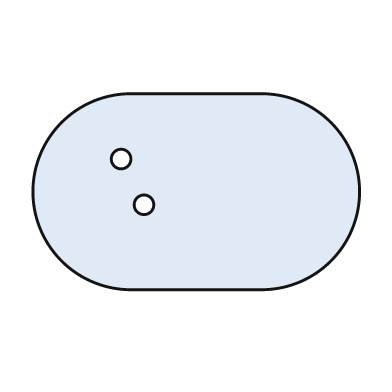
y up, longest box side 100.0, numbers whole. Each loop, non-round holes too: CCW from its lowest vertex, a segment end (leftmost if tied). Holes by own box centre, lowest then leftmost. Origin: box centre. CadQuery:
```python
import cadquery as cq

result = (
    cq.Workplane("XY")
    .moveTo(-20.0, -30.0)
    .lineTo(20.0, -30.0)
    .threePointArc((50.0, 0.0), (20.0, 30.0))
    .lineTo(-20.0, 30.0)
    .threePointArc((-50.0, 0.0), (-20.0, -30.0))
    .close()
    .moveTo(-16.0, -4.0)
    .circle(3.0)
    .moveTo(-23.0, 10.0)
    .circle(3.0)
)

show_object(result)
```